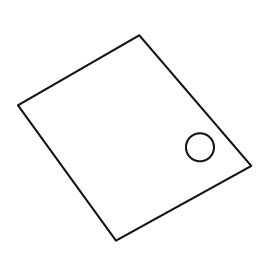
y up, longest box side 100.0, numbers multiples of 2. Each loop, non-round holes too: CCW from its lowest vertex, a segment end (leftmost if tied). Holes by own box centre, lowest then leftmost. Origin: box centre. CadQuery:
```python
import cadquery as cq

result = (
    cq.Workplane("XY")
    .moveTo(-8.0, -44.0)
    .lineTo(50.0, -12.0)
    .lineTo(2.0, 44.0)
    .lineTo(-50.0, 14.0)
    .close()
    .moveTo(28.0, -4.0)
    .circle(6.0)
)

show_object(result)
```